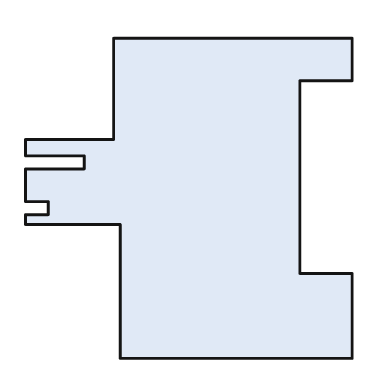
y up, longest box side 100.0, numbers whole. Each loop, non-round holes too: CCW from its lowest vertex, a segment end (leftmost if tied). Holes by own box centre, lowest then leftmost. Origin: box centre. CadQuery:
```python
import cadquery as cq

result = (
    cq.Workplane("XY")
    .moveTo(-21.0, -49.0)
    .lineTo(50.0, -49.0)
    .lineTo(50.0, -23.0)
    .lineTo(34.0, -23.0)
    .lineTo(34.0, 36.0)
    .lineTo(50.0, 36.0)
    .lineTo(50.0, 49.0)
    .lineTo(-23.0, 49.0)
    .lineTo(-23.0, 18.0)
    .lineTo(-50.0, 18.0)
    .lineTo(-50.0, 13.0)
    .lineTo(-32.0, 13.0)
    .lineTo(-32.0, 9.0)
    .lineTo(-50.0, 9.0)
    .lineTo(-50.0, -1.0)
    .lineTo(-43.0, -1.0)
    .lineTo(-43.0, -5.0)
    .lineTo(-50.0, -5.0)
    .lineTo(-50.0, -8.0)
    .lineTo(-21.0, -8.0)
    .close()
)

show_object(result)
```